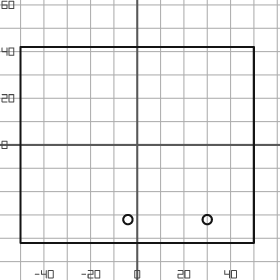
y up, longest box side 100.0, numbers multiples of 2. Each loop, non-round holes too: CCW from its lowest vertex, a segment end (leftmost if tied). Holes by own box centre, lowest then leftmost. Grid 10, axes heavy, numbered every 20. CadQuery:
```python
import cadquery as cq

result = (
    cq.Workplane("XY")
    .moveTo(-50.0, -42.0)
    .lineTo(50.0, -42.0)
    .lineTo(50.0, 42.0)
    .lineTo(-50.0, 42.0)
    .close()
    .moveTo(-4.0, -32.0)
    .circle(2.0)
    .moveTo(30.0, -32.0)
    .circle(2.0)
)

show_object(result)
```